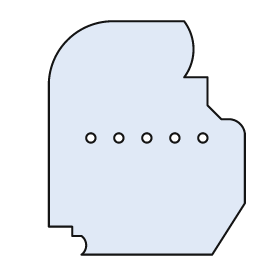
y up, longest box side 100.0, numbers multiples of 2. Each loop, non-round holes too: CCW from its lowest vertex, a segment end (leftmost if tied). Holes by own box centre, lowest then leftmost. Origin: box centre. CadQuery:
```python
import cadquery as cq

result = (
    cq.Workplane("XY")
    .moveTo(-28.0, -50.0)
    .lineTo(28.0, -50.0)
    .lineTo(42.0, -28.0)
    .lineTo(42.0, 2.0)
    .threePointArc((40.0, 6.0), (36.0, 8.0))
    .lineTo(32.0, 8.0)
    .lineTo(26.0, 14.0)
    .lineTo(26.0, 26.0)
    .lineTo(16.0, 26.0)
    .threePointArc((20.0, 38.0), (16.0, 50.0))
    .lineTo(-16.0, 50.0)
    .threePointArc((-34.0, 42.0), (-42.0, 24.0))
    .lineTo(-42.0, -38.0)
    .lineTo(-32.0, -38.0)
    .lineTo(-32.0, -42.0)
    .lineTo(-28.0, -42.0)
    .threePointArc((-26.0, -46.0), (-28.0, -50.0))
    .close()
    .moveTo(-24.0, 0.0)
    .circle(2.0)
    .moveTo(-12.0, 0.0)
    .circle(2.0)
    .moveTo(0.0, 0.0)
    .circle(2.0)
    .moveTo(12.0, 0.0)
    .circle(2.0)
    .moveTo(24.0, 0.0)
    .circle(2.0)
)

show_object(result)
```